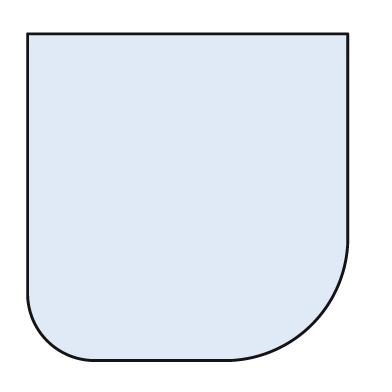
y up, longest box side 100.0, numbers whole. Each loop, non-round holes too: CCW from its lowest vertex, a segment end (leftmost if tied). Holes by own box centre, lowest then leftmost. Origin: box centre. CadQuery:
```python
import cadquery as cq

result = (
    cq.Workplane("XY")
    .moveTo(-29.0, -50.0)
    .lineTo(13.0, -50.0)
    .threePointArc((38.0, -39.0), (49.0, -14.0))
    .lineTo(49.0, 50.0)
    .lineTo(-49.0, 50.0)
    .lineTo(-49.0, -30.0)
    .threePointArc((-43.0, -44.0), (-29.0, -50.0))
    .close()
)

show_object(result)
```